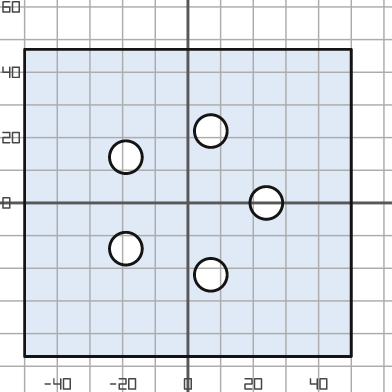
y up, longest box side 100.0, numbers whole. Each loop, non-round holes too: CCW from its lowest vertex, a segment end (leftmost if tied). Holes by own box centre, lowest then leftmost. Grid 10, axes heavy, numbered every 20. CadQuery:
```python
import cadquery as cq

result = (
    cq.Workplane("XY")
    .moveTo(-50.0, -47.0)
    .lineTo(50.0, -47.0)
    .lineTo(50.0, 47.0)
    .lineTo(-50.0, 47.0)
    .close()
    .moveTo(7.0, -22.0)
    .circle(5.0)
    .moveTo(-19.0, -14.0)
    .circle(5.0)
    .moveTo(24.0, 0.0)
    .circle(5.0)
    .moveTo(-19.0, 14.0)
    .circle(5.0)
    .moveTo(7.0, 22.0)
    .circle(5.0)
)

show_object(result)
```